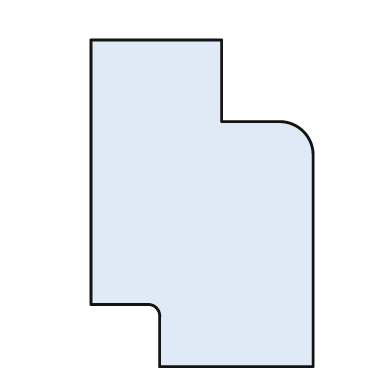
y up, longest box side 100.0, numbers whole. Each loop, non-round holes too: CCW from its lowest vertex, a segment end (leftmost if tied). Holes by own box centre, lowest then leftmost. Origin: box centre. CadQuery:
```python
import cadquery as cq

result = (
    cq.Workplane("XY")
    .moveTo(-13.0, -50.0)
    .lineTo(34.0, -50.0)
    .lineTo(34.0, 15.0)
    .threePointArc((31.0, 22.0), (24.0, 25.0))
    .lineTo(6.0, 25.0)
    .lineTo(6.0, 50.0)
    .lineTo(-34.0, 50.0)
    .lineTo(-34.0, -31.0)
    .lineTo(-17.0, -31.0)
    .threePointArc((-14.0, -32.0), (-13.0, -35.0))
    .close()
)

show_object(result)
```